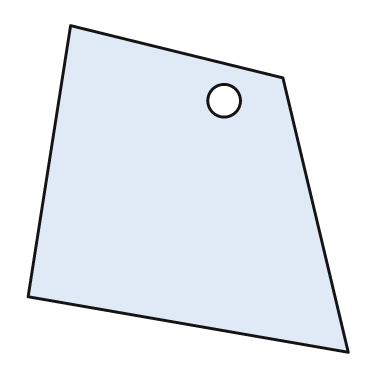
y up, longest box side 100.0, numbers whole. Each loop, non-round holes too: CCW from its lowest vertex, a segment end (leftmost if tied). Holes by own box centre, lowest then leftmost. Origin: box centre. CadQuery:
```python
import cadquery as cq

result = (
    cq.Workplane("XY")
    .moveTo(49.0, -50.0)
    .lineTo(29.0, 34.0)
    .lineTo(-36.0, 50.0)
    .lineTo(-49.0, -33.0)
    .close()
    .moveTo(11.0, 27.0)
    .circle(5.0)
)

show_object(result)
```